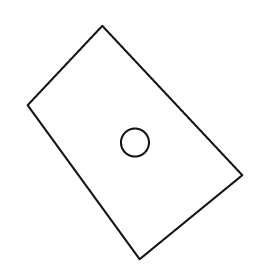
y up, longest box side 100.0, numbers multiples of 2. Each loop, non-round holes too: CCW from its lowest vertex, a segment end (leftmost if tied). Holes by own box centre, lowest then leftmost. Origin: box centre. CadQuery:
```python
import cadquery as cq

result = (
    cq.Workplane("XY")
    .moveTo(2.0, -50.0)
    .lineTo(46.0, -14.0)
    .lineTo(-14.0, 50.0)
    .lineTo(-46.0, 16.0)
    .close()
    .moveTo(0.0, 0.0)
    .circle(6.0)
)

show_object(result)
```